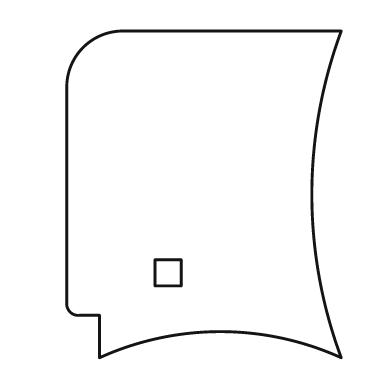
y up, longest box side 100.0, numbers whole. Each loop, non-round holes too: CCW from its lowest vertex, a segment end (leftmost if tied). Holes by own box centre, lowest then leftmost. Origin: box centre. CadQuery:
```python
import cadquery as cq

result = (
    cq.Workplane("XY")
    .moveTo(-32.0, -50.0)
    .threePointArc((5.0, -42.0), (42.0, -50.0))
    .threePointArc((33.0, 0.0), (42.0, 50.0))
    .lineTo(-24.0, 50.0)
    .threePointArc((-37.0, 45.0), (-42.0, 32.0))
    .lineTo(-42.0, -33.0)
    .threePointArc((-41.0, -36.0), (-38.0, -37.0))
    .lineTo(-32.0, -37.0)
    .close()
    .moveTo(-15.0, -28.0)
    .lineTo(-7.0, -28.0)
    .lineTo(-7.0, -20.0)
    .lineTo(-15.0, -20.0)
    .close()
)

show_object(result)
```